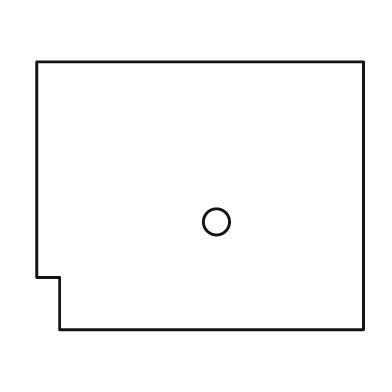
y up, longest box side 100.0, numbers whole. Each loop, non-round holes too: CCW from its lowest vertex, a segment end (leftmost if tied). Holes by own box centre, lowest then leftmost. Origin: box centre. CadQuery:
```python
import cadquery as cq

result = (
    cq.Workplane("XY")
    .moveTo(-43.0, -41.0)
    .lineTo(50.0, -41.0)
    .lineTo(50.0, 41.0)
    .lineTo(-50.0, 41.0)
    .lineTo(-50.0, -25.0)
    .lineTo(-43.0, -25.0)
    .close()
    .moveTo(5.0, -8.0)
    .circle(4.0)
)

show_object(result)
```